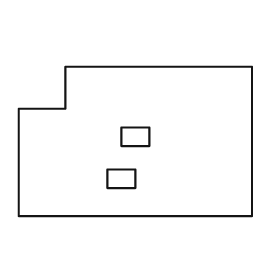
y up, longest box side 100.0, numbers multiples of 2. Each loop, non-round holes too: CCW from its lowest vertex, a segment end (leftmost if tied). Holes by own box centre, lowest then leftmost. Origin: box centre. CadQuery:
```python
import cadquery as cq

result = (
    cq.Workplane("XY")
    .moveTo(-50.0, -32.0)
    .lineTo(50.0, -32.0)
    .lineTo(50.0, 32.0)
    .lineTo(-30.0, 32.0)
    .lineTo(-30.0, 14.0)
    .lineTo(-50.0, 14.0)
    .close()
    .moveTo(-12.0, -20.0)
    .lineTo(0.0, -20.0)
    .lineTo(0.0, -12.0)
    .lineTo(-12.0, -12.0)
    .close()
    .moveTo(-6.0, -2.0)
    .lineTo(6.0, -2.0)
    .lineTo(6.0, 6.0)
    .lineTo(-6.0, 6.0)
    .close()
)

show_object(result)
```